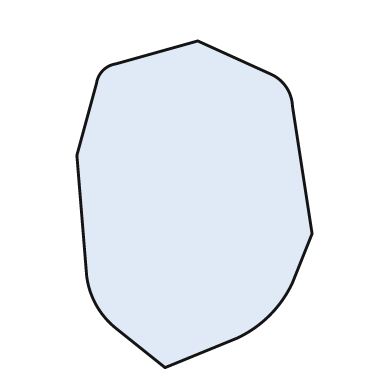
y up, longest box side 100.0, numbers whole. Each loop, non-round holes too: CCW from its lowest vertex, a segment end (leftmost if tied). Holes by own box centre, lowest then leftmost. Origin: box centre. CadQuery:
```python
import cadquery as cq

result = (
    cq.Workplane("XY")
    .moveTo(-9.0, -50.0)
    .lineTo(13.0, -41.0)
    .threePointArc((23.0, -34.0), (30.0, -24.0))
    .lineTo(36.0, -9.0)
    .lineTo(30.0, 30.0)
    .threePointArc((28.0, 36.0), (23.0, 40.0))
    .lineTo(1.0, 50.0)
    .lineTo(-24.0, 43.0)
    .threePointArc((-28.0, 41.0), (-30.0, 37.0))
    .lineTo(-36.0, 15.0)
    .lineTo(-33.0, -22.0)
    .threePointArc((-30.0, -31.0), (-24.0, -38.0))
    .close()
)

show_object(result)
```